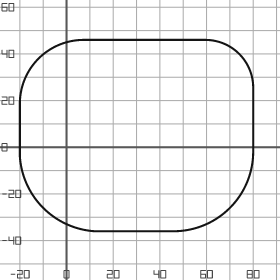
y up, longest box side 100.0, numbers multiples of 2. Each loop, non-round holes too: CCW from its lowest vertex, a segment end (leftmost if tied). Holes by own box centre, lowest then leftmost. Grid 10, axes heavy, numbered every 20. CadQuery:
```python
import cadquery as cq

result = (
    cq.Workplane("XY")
    .moveTo(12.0, -36.0)
    .lineTo(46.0, -36.0)
    .threePointArc((70.0, -26.0), (80.0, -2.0))
    .lineTo(80.0, 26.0)
    .threePointArc((74.0, 40.0), (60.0, 46.0))
    .lineTo(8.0, 46.0)
    .threePointArc((-12.0, 38.0), (-20.0, 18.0))
    .lineTo(-20.0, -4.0)
    .threePointArc((-10.0, -26.0), (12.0, -36.0))
    .close()
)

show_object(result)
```